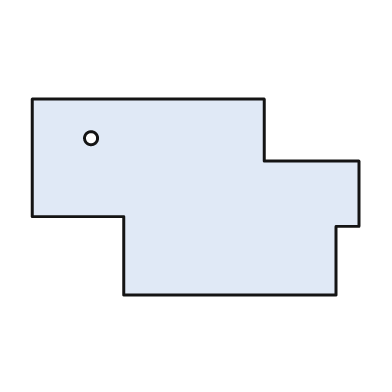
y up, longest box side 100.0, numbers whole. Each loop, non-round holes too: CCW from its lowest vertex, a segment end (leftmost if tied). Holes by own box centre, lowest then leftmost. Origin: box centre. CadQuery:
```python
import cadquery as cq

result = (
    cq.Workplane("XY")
    .moveTo(-22.0, -30.0)
    .lineTo(43.0, -30.0)
    .lineTo(43.0, -9.0)
    .lineTo(50.0, -9.0)
    .lineTo(50.0, 11.0)
    .lineTo(21.0, 11.0)
    .lineTo(21.0, 30.0)
    .lineTo(-50.0, 30.0)
    .lineTo(-50.0, -6.0)
    .lineTo(-22.0, -6.0)
    .close()
    .moveTo(-32.0, 18.0)
    .circle(2.0)
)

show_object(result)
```